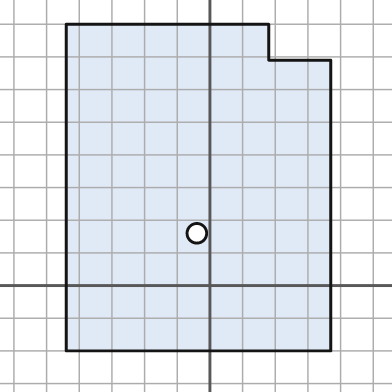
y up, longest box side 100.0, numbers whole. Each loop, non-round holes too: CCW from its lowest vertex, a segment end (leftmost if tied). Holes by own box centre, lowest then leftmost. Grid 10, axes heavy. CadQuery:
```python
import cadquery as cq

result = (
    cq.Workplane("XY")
    .moveTo(-44.0, -20.0)
    .lineTo(37.0, -20.0)
    .lineTo(37.0, 69.0)
    .lineTo(18.0, 69.0)
    .lineTo(18.0, 80.0)
    .lineTo(-44.0, 80.0)
    .close()
    .moveTo(-4.0, 16.0)
    .circle(3.0)
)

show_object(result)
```